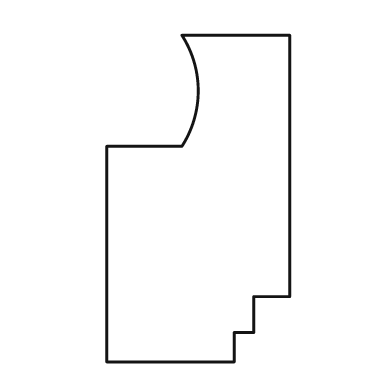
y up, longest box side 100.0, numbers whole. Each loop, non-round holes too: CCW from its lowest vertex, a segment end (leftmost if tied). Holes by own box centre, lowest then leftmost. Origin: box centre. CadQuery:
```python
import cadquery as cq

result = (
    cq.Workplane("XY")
    .moveTo(-28.0, -50.0)
    .lineTo(11.0, -50.0)
    .lineTo(11.0, -41.0)
    .lineTo(17.0, -41.0)
    .lineTo(17.0, -30.0)
    .lineTo(28.0, -30.0)
    .lineTo(28.0, 50.0)
    .lineTo(-5.0, 50.0)
    .threePointArc((0.0, 33.0), (-5.0, 16.0))
    .lineTo(-28.0, 16.0)
    .close()
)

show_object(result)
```